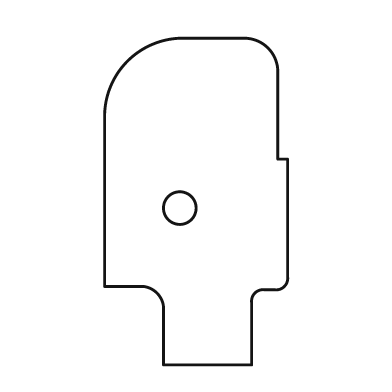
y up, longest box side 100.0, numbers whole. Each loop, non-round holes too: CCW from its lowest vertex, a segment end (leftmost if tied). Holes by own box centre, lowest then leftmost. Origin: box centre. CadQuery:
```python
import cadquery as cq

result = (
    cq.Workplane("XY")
    .moveTo(-10.0, -50.0)
    .lineTo(17.0, -50.0)
    .lineTo(17.0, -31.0)
    .threePointArc((18.0, -28.0), (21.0, -27.0))
    .lineTo(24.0, -27.0)
    .threePointArc((27.0, -26.0), (28.0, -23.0))
    .lineTo(28.0, 13.0)
    .lineTo(25.0, 13.0)
    .lineTo(25.0, 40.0)
    .threePointArc((22.0, 47.0), (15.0, 50.0))
    .lineTo(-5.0, 50.0)
    .threePointArc((-21.0, 43.0), (-28.0, 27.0))
    .lineTo(-28.0, -26.0)
    .lineTo(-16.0, -26.0)
    .threePointArc((-12.0, -28.0), (-10.0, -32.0))
    .close()
    .moveTo(-5.0, -2.0)
    .circle(5.0)
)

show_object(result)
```